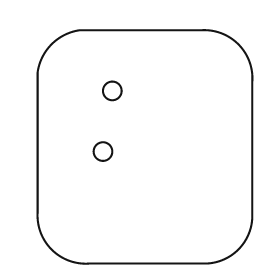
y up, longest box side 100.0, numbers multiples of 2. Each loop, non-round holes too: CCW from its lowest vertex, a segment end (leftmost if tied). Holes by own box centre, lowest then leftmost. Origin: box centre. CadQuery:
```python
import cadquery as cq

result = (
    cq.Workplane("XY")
    .moveTo(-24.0, -50.0)
    .lineTo(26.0, -50.0)
    .threePointArc((40.0, -44.0), (46.0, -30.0))
    .lineTo(46.0, 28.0)
    .threePointArc((40.0, 44.0), (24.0, 50.0))
    .lineTo(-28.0, 50.0)
    .threePointArc((-40.0, 44.0), (-46.0, 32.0))
    .lineTo(-46.0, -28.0)
    .threePointArc((-40.0, -44.0), (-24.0, -50.0))
    .close()
    .moveTo(-18.0, -2.0)
    .circle(4.0)
    .moveTo(-14.0, 24.0)
    .circle(4.0)
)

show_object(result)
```